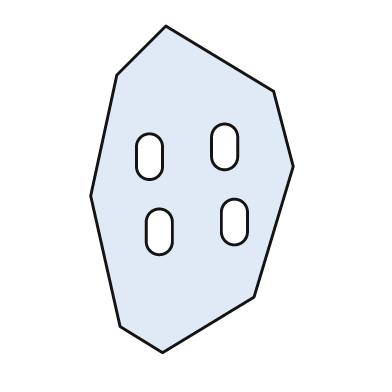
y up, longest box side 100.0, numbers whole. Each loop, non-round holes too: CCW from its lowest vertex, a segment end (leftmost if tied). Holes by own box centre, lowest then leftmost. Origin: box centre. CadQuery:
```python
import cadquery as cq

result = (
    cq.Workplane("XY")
    .moveTo(-9.0, -50.0)
    .lineTo(19.0, -33.0)
    .lineTo(31.0, 7.0)
    .lineTo(25.0, 30.0)
    .lineTo(-8.0, 50.0)
    .lineTo(-23.0, 35.0)
    .lineTo(-31.0, -2.0)
    .lineTo(-22.0, -42.0)
    .close()
    .moveTo(-14.0, -16.0)
    .threePointArc((-10.0, -20.0), (-6.0, -16.0))
    .lineTo(-6.0, -10.0)
    .threePointArc((-10.0, -6.0), (-14.0, -10.0))
    .close()
    .moveTo(9.0, -13.0)
    .threePointArc((13.0, -17.0), (17.0, -13.0))
    .lineTo(17.0, -7.0)
    .threePointArc((13.0, -3.0), (9.0, -7.0))
    .close()
    .moveTo(-17.0, 7.0)
    .threePointArc((-13.0, 3.0), (-9.0, 7.0))
    .lineTo(-9.0, 13.0)
    .threePointArc((-13.0, 17.0), (-17.0, 13.0))
    .close()
    .moveTo(6.0, 10.0)
    .threePointArc((10.0, 6.0), (14.0, 10.0))
    .lineTo(14.0, 16.0)
    .threePointArc((10.0, 20.0), (6.0, 16.0))
    .close()
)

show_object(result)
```